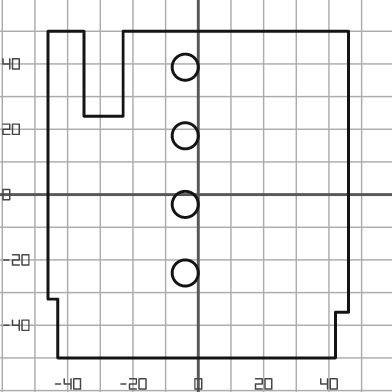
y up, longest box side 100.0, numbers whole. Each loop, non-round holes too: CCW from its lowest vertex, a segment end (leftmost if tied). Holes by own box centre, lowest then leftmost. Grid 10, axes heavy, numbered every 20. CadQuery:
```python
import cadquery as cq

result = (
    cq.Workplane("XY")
    .moveTo(-43.0, -50.0)
    .lineTo(42.0, -50.0)
    .lineTo(42.0, -36.0)
    .lineTo(46.0, -36.0)
    .lineTo(46.0, 50.0)
    .lineTo(-23.0, 50.0)
    .lineTo(-23.0, 24.0)
    .lineTo(-35.0, 24.0)
    .lineTo(-35.0, 50.0)
    .lineTo(-46.0, 50.0)
    .lineTo(-46.0, -32.0)
    .lineTo(-43.0, -32.0)
    .close()
    .moveTo(-4.0, -24.0)
    .circle(4.0)
    .moveTo(-4.0, -3.0)
    .circle(4.0)
    .moveTo(-4.0, 18.0)
    .circle(4.0)
    .moveTo(-4.0, 39.0)
    .circle(4.0)
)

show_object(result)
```